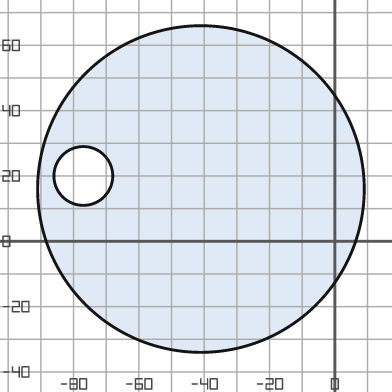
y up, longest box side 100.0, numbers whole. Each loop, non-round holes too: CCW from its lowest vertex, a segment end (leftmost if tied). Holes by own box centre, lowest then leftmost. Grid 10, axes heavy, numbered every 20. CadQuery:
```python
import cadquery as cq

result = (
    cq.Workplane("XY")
    .moveTo(-41.0, 16.0)
    .circle(50.0)
    .moveTo(-77.0, 20.0)
    .circle(9.0)
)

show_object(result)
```